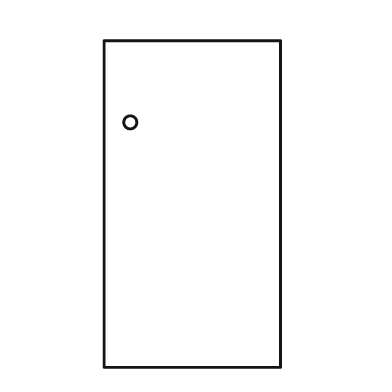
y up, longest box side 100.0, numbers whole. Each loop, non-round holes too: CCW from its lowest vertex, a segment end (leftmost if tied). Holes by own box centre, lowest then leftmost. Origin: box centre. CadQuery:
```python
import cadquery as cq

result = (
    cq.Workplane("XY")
    .moveTo(-27.0, -50.0)
    .lineTo(27.0, -50.0)
    .lineTo(27.0, 50.0)
    .lineTo(-27.0, 50.0)
    .close()
    .moveTo(-19.0, 25.0)
    .circle(2.0)
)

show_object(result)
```